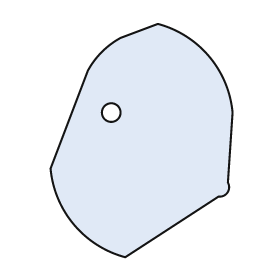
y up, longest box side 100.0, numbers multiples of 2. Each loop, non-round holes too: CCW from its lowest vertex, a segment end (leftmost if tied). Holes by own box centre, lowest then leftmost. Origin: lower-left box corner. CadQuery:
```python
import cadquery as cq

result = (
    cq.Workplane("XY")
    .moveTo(32.0, 0.0)
    .lineTo(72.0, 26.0)
    .threePointArc((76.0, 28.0), (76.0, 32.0))
    .lineTo(78.0, 62.0)
    .threePointArc((68.0, 86.0), (46.0, 100.0))
    .lineTo(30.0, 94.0)
    .threePointArc((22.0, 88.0), (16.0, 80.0))
    .lineTo(0.0, 38.0)
    .threePointArc((10.0, 14.0), (32.0, 0.0))
    .close()
    .moveTo(26.0, 62.0)
    .circle(4.0)
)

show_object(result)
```